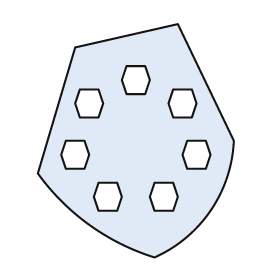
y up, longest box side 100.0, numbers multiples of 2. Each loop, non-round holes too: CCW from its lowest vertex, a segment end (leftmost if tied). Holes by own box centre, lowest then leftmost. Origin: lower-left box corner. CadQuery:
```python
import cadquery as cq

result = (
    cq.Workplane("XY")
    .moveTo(50.0, 0.0)
    .threePointArc((74.0, 20.0), (84.0, 50.0))
    .lineTo(60.0, 100.0)
    .lineTo(16.0, 90.0)
    .lineTo(0.0, 36.0)
    .threePointArc((22.0, 14.0), (50.0, 0.0))
    .close()
    .moveTo(26.0, 20.0)
    .lineTo(34.0, 20.0)
    .lineTo(36.0, 26.0)
    .lineTo(34.0, 32.0)
    .lineTo(26.0, 32.0)
    .lineTo(24.0, 26.0)
    .close()
    .moveTo(50.0, 20.0)
    .lineTo(58.0, 20.0)
    .lineTo(60.0, 26.0)
    .lineTo(58.0, 32.0)
    .lineTo(50.0, 32.0)
    .lineTo(48.0, 26.0)
    .close()
    .moveTo(12.0, 38.0)
    .lineTo(20.0, 38.0)
    .lineTo(22.0, 44.0)
    .lineTo(20.0, 50.0)
    .lineTo(12.0, 50.0)
    .lineTo(10.0, 44.0)
    .close()
    .moveTo(64.0, 38.0)
    .lineTo(72.0, 38.0)
    .lineTo(74.0, 44.0)
    .lineTo(72.0, 50.0)
    .lineTo(64.0, 50.0)
    .lineTo(62.0, 44.0)
    .close()
    .moveTo(18.0, 60.0)
    .lineTo(26.0, 60.0)
    .lineTo(28.0, 66.0)
    .lineTo(26.0, 72.0)
    .lineTo(18.0, 72.0)
    .lineTo(16.0, 66.0)
    .close()
    .moveTo(58.0, 60.0)
    .lineTo(66.0, 60.0)
    .lineTo(68.0, 66.0)
    .lineTo(66.0, 72.0)
    .lineTo(58.0, 72.0)
    .lineTo(56.0, 66.0)
    .close()
    .moveTo(38.0, 70.0)
    .lineTo(46.0, 70.0)
    .lineTo(48.0, 76.0)
    .lineTo(46.0, 82.0)
    .lineTo(38.0, 82.0)
    .lineTo(36.0, 76.0)
    .close()
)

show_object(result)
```